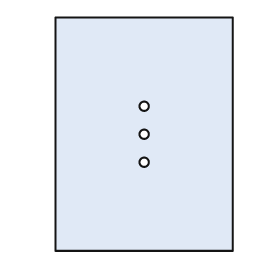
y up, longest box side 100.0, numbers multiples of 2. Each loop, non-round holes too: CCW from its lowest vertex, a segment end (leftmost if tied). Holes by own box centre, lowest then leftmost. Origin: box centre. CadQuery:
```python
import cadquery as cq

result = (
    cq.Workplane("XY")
    .moveTo(-38.0, -50.0)
    .lineTo(38.0, -50.0)
    .lineTo(38.0, 50.0)
    .lineTo(-38.0, 50.0)
    .close()
    .moveTo(0.0, -12.0)
    .circle(2.0)
    .moveTo(0.0, 0.0)
    .circle(2.0)
    .moveTo(0.0, 12.0)
    .circle(2.0)
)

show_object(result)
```